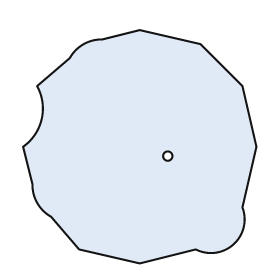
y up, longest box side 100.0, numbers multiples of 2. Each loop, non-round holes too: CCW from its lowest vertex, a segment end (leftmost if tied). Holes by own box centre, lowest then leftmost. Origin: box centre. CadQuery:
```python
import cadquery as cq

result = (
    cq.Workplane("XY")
    .moveTo(0.0, -50.0)
    .lineTo(24.0, -44.0)
    .threePointArc((40.0, -42.0), (44.0, -26.0))
    .lineTo(50.0, 0.0)
    .lineTo(44.0, 26.0)
    .lineTo(26.0, 44.0)
    .lineTo(0.0, 50.0)
    .lineTo(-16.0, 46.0)
    .threePointArc((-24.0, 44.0), (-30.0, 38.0))
    .lineTo(-44.0, 26.0)
    .threePointArc((-42.0, 12.0), (-50.0, 0.0))
    .lineTo(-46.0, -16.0)
    .threePointArc((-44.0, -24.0), (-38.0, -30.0))
    .lineTo(-26.0, -44.0)
    .close()
    .moveTo(12.0, -4.0)
    .circle(2.0)
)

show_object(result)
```